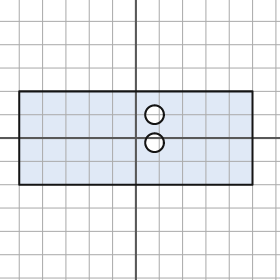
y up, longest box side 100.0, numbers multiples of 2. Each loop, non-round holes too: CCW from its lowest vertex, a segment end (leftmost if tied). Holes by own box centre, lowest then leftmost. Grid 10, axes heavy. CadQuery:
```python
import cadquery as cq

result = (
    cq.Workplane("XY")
    .moveTo(-50.0, -20.0)
    .lineTo(50.0, -20.0)
    .lineTo(50.0, 20.0)
    .lineTo(-50.0, 20.0)
    .close()
    .moveTo(8.0, -2.0)
    .circle(4.0)
    .moveTo(8.0, 10.0)
    .circle(4.0)
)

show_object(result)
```